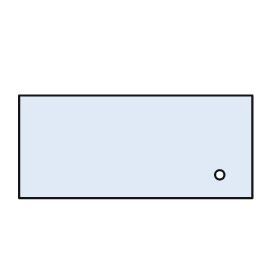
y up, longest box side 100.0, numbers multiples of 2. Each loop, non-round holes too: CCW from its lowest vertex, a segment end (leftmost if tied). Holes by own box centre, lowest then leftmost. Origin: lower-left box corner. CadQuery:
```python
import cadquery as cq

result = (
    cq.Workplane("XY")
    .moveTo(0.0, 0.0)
    .lineTo(100.0, 0.0)
    .lineTo(100.0, 44.0)
    .lineTo(0.0, 44.0)
    .close()
    .moveTo(86.0, 10.0)
    .circle(2.0)
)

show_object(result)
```